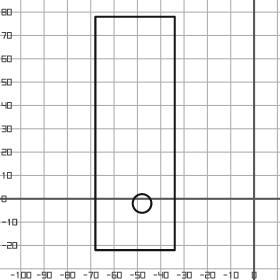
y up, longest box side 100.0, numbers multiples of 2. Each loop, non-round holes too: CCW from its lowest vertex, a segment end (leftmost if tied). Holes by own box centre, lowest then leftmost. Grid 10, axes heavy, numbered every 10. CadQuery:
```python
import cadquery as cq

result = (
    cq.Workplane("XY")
    .moveTo(-68.0, -22.0)
    .lineTo(-34.0, -22.0)
    .lineTo(-34.0, 78.0)
    .lineTo(-68.0, 78.0)
    .close()
    .moveTo(-48.0, -2.0)
    .circle(4.0)
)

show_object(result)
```